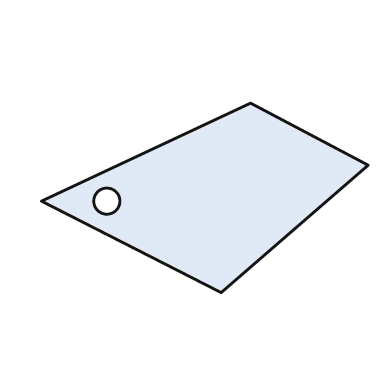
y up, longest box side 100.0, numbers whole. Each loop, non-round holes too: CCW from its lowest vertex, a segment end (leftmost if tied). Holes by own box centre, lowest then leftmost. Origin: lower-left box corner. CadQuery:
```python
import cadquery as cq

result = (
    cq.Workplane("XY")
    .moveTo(55.0, 0.0)
    .lineTo(100.0, 39.0)
    .lineTo(64.0, 58.0)
    .lineTo(0.0, 28.0)
    .close()
    .moveTo(20.0, 28.0)
    .circle(4.0)
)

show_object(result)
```